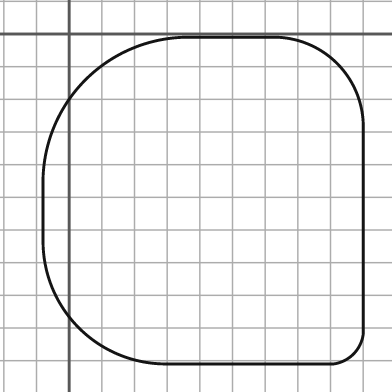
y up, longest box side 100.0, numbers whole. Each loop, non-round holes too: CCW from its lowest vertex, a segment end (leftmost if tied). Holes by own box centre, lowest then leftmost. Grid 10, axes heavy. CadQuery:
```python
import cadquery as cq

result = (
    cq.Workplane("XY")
    .moveTo(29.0, -101.0)
    .lineTo(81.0, -101.0)
    .threePointArc((87.0, -98.0), (90.0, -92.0))
    .lineTo(90.0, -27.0)
    .threePointArc((82.0, -9.0), (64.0, -1.0))
    .lineTo(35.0, -1.0)
    .threePointArc((5.0, -14.0), (-8.0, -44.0))
    .lineTo(-8.0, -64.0)
    .threePointArc((3.0, -90.0), (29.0, -101.0))
    .close()
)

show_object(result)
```